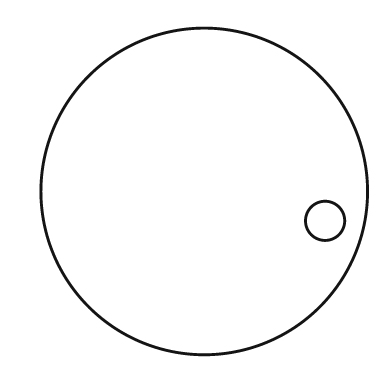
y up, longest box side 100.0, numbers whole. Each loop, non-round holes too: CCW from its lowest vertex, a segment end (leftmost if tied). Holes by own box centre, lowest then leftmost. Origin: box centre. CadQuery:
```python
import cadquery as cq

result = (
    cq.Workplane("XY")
    .moveTo(0.0, 0.0)
    .circle(50.0)
    .moveTo(37.0, -9.0)
    .circle(6.0)
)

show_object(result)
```